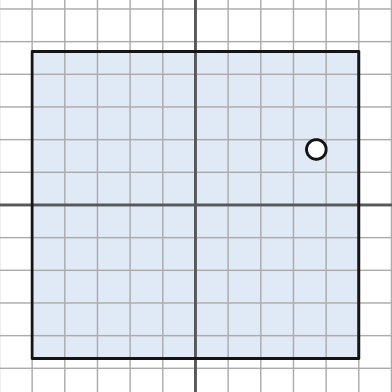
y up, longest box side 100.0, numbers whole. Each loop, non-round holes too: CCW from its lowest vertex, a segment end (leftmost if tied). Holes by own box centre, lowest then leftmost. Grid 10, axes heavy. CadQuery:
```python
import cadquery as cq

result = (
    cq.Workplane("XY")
    .moveTo(-50.0, -47.0)
    .lineTo(50.0, -47.0)
    .lineTo(50.0, 47.0)
    .lineTo(-50.0, 47.0)
    .close()
    .moveTo(37.0, 17.0)
    .circle(3.0)
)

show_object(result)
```